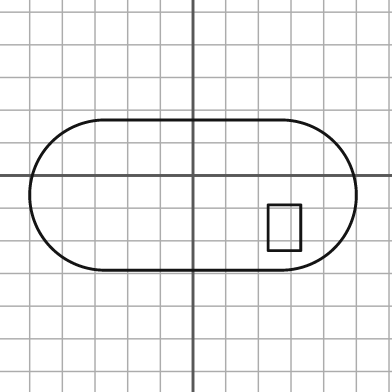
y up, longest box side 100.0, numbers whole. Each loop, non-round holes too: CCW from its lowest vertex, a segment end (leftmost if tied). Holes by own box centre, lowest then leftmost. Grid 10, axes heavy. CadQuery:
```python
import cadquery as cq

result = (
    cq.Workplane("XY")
    .moveTo(-27.0, -29.0)
    .lineTo(27.0, -29.0)
    .threePointArc((50.0, -6.0), (27.0, 17.0))
    .lineTo(-27.0, 17.0)
    .threePointArc((-50.0, -6.0), (-27.0, -29.0))
    .close()
    .moveTo(23.0, -23.0)
    .lineTo(33.0, -23.0)
    .lineTo(33.0, -9.0)
    .lineTo(23.0, -9.0)
    .close()
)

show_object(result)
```